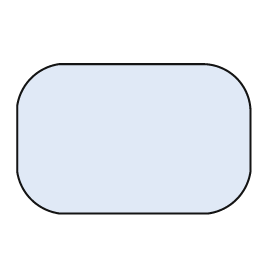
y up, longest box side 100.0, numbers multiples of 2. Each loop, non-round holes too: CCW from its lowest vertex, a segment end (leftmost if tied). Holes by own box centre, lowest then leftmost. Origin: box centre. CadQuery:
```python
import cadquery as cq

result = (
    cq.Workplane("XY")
    .moveTo(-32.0, -32.0)
    .lineTo(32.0, -32.0)
    .threePointArc((44.0, -26.0), (50.0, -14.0))
    .lineTo(50.0, 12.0)
    .threePointArc((44.0, 26.0), (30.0, 32.0))
    .lineTo(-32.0, 32.0)
    .threePointArc((-44.0, 26.0), (-50.0, 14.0))
    .lineTo(-50.0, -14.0)
    .threePointArc((-44.0, -26.0), (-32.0, -32.0))
    .close()
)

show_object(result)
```